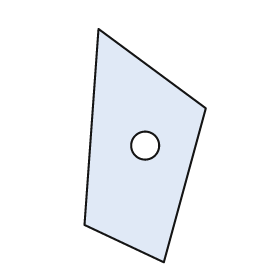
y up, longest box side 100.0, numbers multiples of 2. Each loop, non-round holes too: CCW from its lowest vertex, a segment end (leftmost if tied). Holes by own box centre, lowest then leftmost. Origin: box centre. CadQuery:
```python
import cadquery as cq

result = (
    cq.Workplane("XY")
    .moveTo(8.0, -50.0)
    .lineTo(26.0, 16.0)
    .lineTo(-20.0, 50.0)
    .lineTo(-26.0, -34.0)
    .close()
    .moveTo(0.0, 0.0)
    .circle(6.0)
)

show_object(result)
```